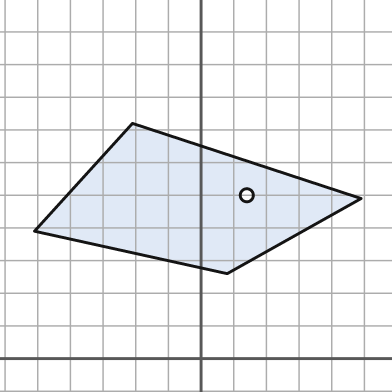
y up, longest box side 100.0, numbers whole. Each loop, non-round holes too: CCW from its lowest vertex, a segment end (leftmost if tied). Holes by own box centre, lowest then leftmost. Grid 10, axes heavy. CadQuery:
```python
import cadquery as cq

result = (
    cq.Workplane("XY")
    .moveTo(8.0, 26.0)
    .lineTo(49.0, 49.0)
    .lineTo(-21.0, 72.0)
    .lineTo(-51.0, 39.0)
    .close()
    .moveTo(14.0, 50.0)
    .circle(2.0)
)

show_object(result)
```